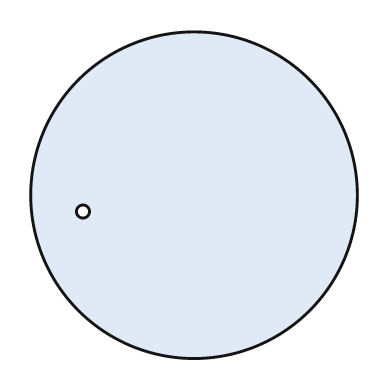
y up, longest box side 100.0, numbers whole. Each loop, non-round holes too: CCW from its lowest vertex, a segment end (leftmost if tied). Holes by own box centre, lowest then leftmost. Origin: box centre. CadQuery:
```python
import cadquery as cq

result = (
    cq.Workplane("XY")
    .moveTo(0.0, 0.0)
    .circle(50.0)
    .moveTo(-34.0, -5.0)
    .circle(2.0)
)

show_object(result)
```